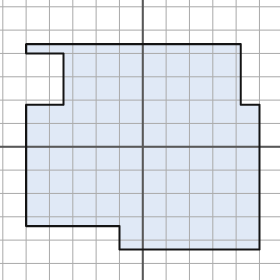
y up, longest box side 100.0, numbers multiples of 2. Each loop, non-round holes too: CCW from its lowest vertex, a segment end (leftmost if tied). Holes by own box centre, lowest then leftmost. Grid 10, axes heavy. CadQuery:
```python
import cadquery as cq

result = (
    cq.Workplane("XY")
    .moveTo(-10.0, -44.0)
    .lineTo(50.0, -44.0)
    .lineTo(50.0, 18.0)
    .lineTo(42.0, 18.0)
    .lineTo(42.0, 44.0)
    .lineTo(-50.0, 44.0)
    .lineTo(-50.0, 40.0)
    .lineTo(-34.0, 40.0)
    .lineTo(-34.0, 18.0)
    .lineTo(-50.0, 18.0)
    .lineTo(-50.0, -34.0)
    .lineTo(-10.0, -34.0)
    .close()
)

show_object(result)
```